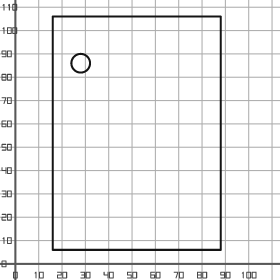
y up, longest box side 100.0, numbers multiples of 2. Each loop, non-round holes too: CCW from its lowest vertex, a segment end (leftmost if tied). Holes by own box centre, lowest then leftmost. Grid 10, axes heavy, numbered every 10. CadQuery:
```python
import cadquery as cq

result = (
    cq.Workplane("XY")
    .moveTo(16.0, 6.0)
    .lineTo(88.0, 6.0)
    .lineTo(88.0, 106.0)
    .lineTo(16.0, 106.0)
    .close()
    .moveTo(28.0, 86.0)
    .circle(4.0)
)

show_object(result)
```